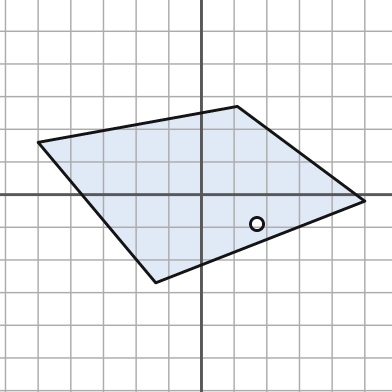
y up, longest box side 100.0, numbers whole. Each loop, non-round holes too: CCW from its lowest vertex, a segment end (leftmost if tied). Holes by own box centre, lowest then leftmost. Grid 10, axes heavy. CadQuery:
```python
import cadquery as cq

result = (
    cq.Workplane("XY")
    .moveTo(-14.0, -27.0)
    .lineTo(50.0, -2.0)
    .lineTo(11.0, 27.0)
    .lineTo(-50.0, 16.0)
    .close()
    .moveTo(17.0, -9.0)
    .circle(2.0)
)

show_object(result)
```